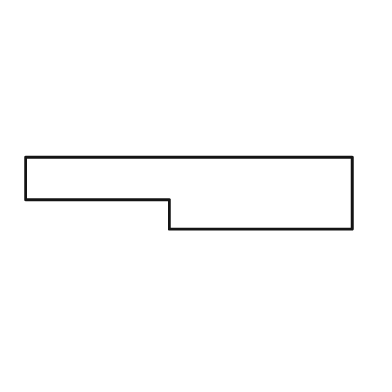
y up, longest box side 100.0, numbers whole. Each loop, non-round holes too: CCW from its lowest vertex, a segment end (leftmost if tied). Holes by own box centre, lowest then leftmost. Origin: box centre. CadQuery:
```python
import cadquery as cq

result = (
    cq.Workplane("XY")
    .moveTo(-6.0, -11.0)
    .lineTo(50.0, -11.0)
    .lineTo(50.0, 11.0)
    .lineTo(-50.0, 11.0)
    .lineTo(-50.0, -2.0)
    .lineTo(-6.0, -2.0)
    .close()
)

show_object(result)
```